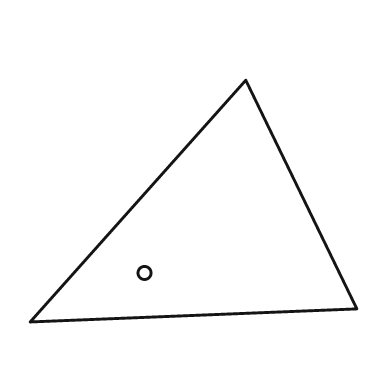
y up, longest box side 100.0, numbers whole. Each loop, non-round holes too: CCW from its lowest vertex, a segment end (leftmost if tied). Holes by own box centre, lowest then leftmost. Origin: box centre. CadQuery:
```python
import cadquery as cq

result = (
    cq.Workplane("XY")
    .moveTo(-50.0, -37.0)
    .lineTo(50.0, -33.0)
    .lineTo(16.0, 37.0)
    .close()
    .moveTo(-15.0, -22.0)
    .circle(2.0)
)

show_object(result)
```